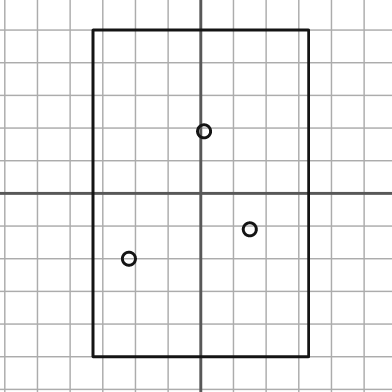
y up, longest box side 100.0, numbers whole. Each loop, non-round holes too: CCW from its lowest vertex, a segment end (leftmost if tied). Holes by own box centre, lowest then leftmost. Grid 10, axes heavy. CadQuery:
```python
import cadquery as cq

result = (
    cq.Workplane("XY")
    .moveTo(-33.0, -50.0)
    .lineTo(33.0, -50.0)
    .lineTo(33.0, 50.0)
    .lineTo(-33.0, 50.0)
    .close()
    .moveTo(-22.0, -20.0)
    .circle(2.0)
    .moveTo(15.0, -11.0)
    .circle(2.0)
    .moveTo(1.0, 19.0)
    .circle(2.0)
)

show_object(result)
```